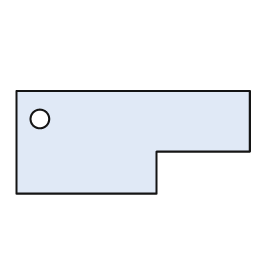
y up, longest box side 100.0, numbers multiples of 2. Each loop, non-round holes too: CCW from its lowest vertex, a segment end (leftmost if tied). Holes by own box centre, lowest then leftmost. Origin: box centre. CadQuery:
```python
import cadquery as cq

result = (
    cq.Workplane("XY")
    .moveTo(-50.0, -22.0)
    .lineTo(10.0, -22.0)
    .lineTo(10.0, -4.0)
    .lineTo(50.0, -4.0)
    .lineTo(50.0, 22.0)
    .lineTo(-50.0, 22.0)
    .close()
    .moveTo(-40.0, 10.0)
    .circle(4.0)
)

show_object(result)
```